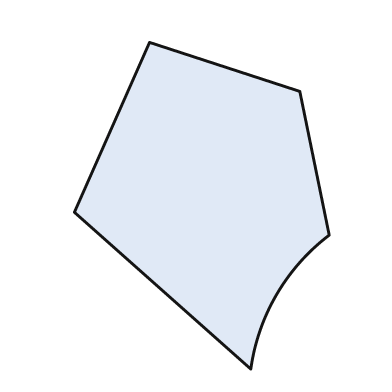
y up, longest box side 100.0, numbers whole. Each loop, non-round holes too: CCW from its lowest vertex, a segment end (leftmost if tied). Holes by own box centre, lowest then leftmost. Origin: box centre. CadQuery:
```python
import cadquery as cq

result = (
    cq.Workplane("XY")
    .moveTo(15.0, -50.0)
    .threePointArc((23.0, -27.0), (39.0, -9.0))
    .lineTo(30.0, 35.0)
    .lineTo(-16.0, 50.0)
    .lineTo(-39.0, -2.0)
    .close()
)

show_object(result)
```